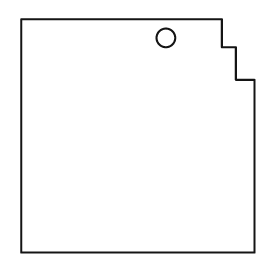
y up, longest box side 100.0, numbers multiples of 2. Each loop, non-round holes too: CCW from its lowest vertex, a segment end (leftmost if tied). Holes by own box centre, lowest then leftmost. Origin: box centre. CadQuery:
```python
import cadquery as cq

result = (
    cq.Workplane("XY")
    .moveTo(-50.0, -50.0)
    .lineTo(50.0, -50.0)
    .lineTo(50.0, 24.0)
    .lineTo(42.0, 24.0)
    .lineTo(42.0, 38.0)
    .lineTo(36.0, 38.0)
    .lineTo(36.0, 50.0)
    .lineTo(-50.0, 50.0)
    .close()
    .moveTo(12.0, 42.0)
    .circle(4.0)
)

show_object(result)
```